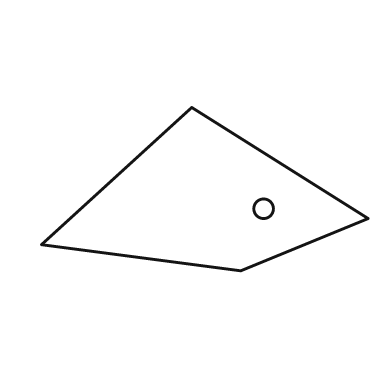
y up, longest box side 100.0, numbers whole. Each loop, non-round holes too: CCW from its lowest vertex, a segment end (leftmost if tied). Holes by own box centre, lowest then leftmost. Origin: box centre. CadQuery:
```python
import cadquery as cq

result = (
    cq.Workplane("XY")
    .moveTo(11.0, -25.0)
    .lineTo(50.0, -9.0)
    .lineTo(-4.0, 25.0)
    .lineTo(-50.0, -17.0)
    .close()
    .moveTo(18.0, -6.0)
    .circle(3.0)
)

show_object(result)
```